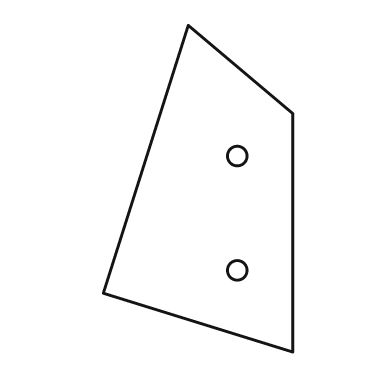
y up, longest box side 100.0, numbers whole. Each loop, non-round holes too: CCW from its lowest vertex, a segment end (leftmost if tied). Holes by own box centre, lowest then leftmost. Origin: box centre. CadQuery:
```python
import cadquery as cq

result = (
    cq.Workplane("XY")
    .moveTo(29.0, -50.0)
    .lineTo(29.0, 23.0)
    .lineTo(-3.0, 50.0)
    .lineTo(-29.0, -32.0)
    .close()
    .moveTo(12.0, -25.0)
    .circle(3.0)
    .moveTo(12.0, 10.0)
    .circle(3.0)
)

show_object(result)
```